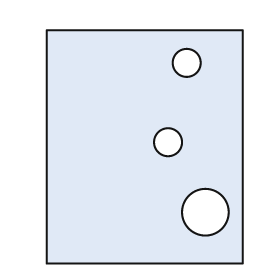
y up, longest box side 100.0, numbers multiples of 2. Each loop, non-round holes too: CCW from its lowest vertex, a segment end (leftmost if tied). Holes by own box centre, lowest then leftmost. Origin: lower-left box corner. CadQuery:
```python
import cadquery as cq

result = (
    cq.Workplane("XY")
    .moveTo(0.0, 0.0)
    .lineTo(84.0, 0.0)
    .lineTo(84.0, 100.0)
    .lineTo(0.0, 100.0)
    .close()
    .moveTo(68.0, 22.0)
    .circle(10.0)
    .moveTo(52.0, 52.0)
    .circle(6.0)
    .moveTo(60.0, 86.0)
    .circle(6.0)
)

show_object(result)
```